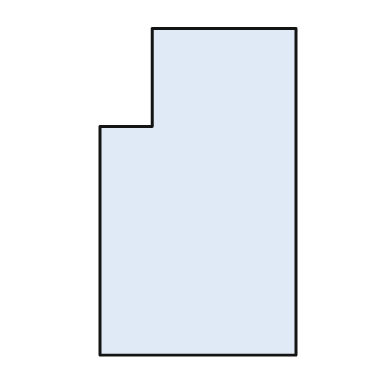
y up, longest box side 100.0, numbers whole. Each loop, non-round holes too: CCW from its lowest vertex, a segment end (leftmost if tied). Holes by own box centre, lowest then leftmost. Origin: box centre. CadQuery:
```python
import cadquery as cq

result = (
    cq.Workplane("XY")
    .moveTo(-30.0, -50.0)
    .lineTo(30.0, -50.0)
    .lineTo(30.0, 50.0)
    .lineTo(-14.0, 50.0)
    .lineTo(-14.0, 20.0)
    .lineTo(-30.0, 20.0)
    .close()
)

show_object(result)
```